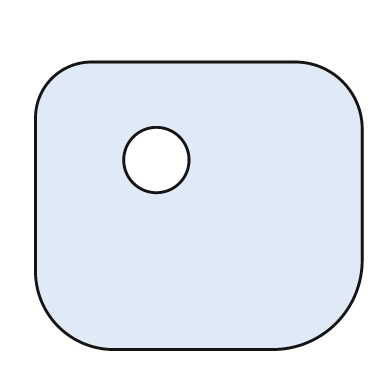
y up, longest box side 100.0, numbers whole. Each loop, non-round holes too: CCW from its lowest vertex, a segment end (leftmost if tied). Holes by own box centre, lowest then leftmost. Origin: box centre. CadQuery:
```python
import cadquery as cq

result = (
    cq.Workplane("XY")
    .moveTo(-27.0, -44.0)
    .lineTo(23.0, -44.0)
    .threePointArc((42.0, -36.0), (50.0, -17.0))
    .lineTo(50.0, 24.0)
    .threePointArc((44.0, 38.0), (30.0, 44.0))
    .lineTo(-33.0, 44.0)
    .threePointArc((-45.0, 39.0), (-50.0, 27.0))
    .lineTo(-50.0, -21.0)
    .threePointArc((-43.0, -37.0), (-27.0, -44.0))
    .close()
    .moveTo(-13.0, 14.0)
    .circle(10.0)
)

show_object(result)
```